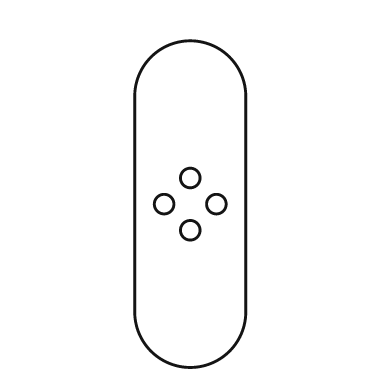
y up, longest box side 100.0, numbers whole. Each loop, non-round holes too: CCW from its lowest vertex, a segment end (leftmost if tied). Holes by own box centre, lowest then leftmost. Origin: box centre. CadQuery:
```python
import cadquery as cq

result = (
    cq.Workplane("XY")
    .moveTo(-17.0, -33.0)
    .threePointArc((0.0, -50.0), (17.0, -33.0))
    .lineTo(17.0, 33.0)
    .threePointArc((0.0, 50.0), (-17.0, 33.0))
    .close()
    .moveTo(0.0, -8.0)
    .circle(3.0)
    .moveTo(-8.0, 0.0)
    .circle(3.0)
    .moveTo(8.0, 0.0)
    .circle(3.0)
    .moveTo(0.0, 8.0)
    .circle(3.0)
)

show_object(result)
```